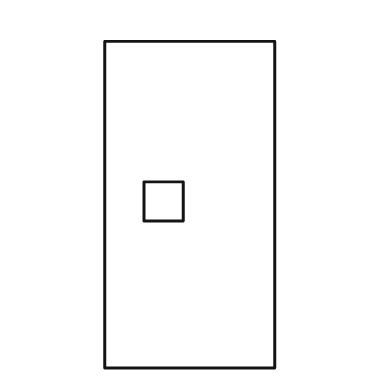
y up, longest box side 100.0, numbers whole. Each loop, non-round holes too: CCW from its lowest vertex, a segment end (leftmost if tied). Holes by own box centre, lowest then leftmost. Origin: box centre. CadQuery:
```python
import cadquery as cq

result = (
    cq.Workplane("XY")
    .moveTo(-26.0, -50.0)
    .lineTo(26.0, -50.0)
    .lineTo(26.0, 50.0)
    .lineTo(-26.0, 50.0)
    .close()
    .moveTo(-14.0, -5.0)
    .lineTo(-2.0, -5.0)
    .lineTo(-2.0, 7.0)
    .lineTo(-14.0, 7.0)
    .close()
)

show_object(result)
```